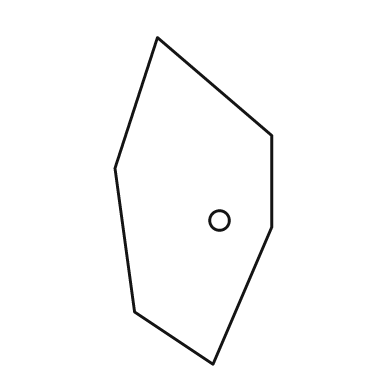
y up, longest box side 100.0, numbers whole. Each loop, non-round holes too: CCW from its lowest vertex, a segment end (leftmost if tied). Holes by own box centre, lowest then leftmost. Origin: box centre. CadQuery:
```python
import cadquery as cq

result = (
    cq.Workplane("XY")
    .moveTo(6.0, -50.0)
    .lineTo(24.0, -8.0)
    .lineTo(24.0, 20.0)
    .lineTo(-11.0, 50.0)
    .lineTo(-24.0, 10.0)
    .lineTo(-18.0, -34.0)
    .close()
    .moveTo(8.0, -6.0)
    .circle(3.0)
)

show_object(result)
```